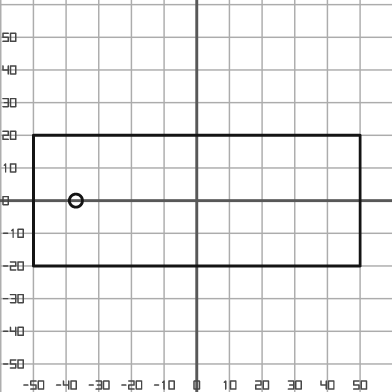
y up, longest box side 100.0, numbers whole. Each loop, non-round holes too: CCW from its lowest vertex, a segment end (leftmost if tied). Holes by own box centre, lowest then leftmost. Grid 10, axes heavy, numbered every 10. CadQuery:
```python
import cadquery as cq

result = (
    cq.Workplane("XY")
    .moveTo(-50.0, -20.0)
    .lineTo(50.0, -20.0)
    .lineTo(50.0, 20.0)
    .lineTo(-50.0, 20.0)
    .close()
    .moveTo(-37.0, 0.0)
    .circle(2.0)
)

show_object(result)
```